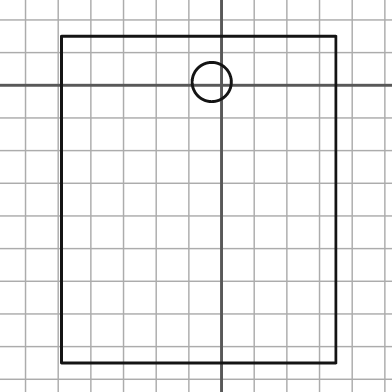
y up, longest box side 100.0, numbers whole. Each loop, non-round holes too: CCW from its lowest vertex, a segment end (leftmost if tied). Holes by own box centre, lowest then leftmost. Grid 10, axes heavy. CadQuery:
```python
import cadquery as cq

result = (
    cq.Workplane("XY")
    .moveTo(-49.0, -85.0)
    .lineTo(35.0, -85.0)
    .lineTo(35.0, 15.0)
    .lineTo(-49.0, 15.0)
    .close()
    .moveTo(-3.0, 1.0)
    .circle(6.0)
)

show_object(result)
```